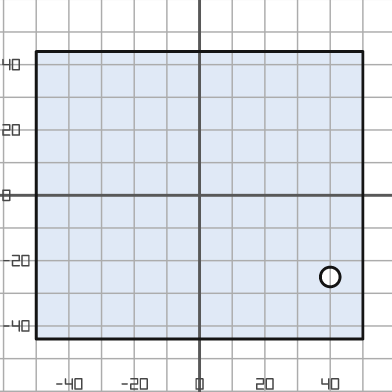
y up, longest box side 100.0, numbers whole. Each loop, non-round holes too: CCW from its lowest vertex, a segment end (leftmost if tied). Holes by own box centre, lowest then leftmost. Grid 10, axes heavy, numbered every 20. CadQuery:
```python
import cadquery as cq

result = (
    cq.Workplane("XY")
    .moveTo(-50.0, -44.0)
    .lineTo(50.0, -44.0)
    .lineTo(50.0, 44.0)
    .lineTo(-50.0, 44.0)
    .close()
    .moveTo(40.0, -25.0)
    .circle(3.0)
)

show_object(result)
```